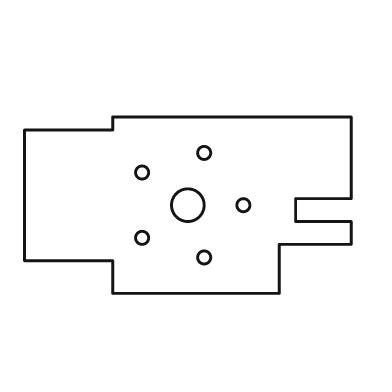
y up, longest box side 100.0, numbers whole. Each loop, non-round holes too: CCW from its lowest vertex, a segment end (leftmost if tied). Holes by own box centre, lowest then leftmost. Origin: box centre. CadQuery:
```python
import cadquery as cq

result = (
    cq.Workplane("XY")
    .moveTo(-23.0, -27.0)
    .lineTo(28.0, -27.0)
    .lineTo(28.0, -12.0)
    .lineTo(50.0, -12.0)
    .lineTo(50.0, -5.0)
    .lineTo(33.0, -5.0)
    .lineTo(33.0, 2.0)
    .lineTo(50.0, 2.0)
    .lineTo(50.0, 27.0)
    .lineTo(-23.0, 27.0)
    .lineTo(-23.0, 23.0)
    .lineTo(-50.0, 23.0)
    .lineTo(-50.0, -17.0)
    .lineTo(-23.0, -17.0)
    .close()
    .moveTo(5.0, -16.0)
    .circle(2.0)
    .moveTo(-14.0, -10.0)
    .circle(2.0)
    .moveTo(0.0, 0.0)
    .circle(5.0)
    .moveTo(17.0, 0.0)
    .circle(2.0)
    .moveTo(-14.0, 10.0)
    .circle(2.0)
    .moveTo(5.0, 16.0)
    .circle(2.0)
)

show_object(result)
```